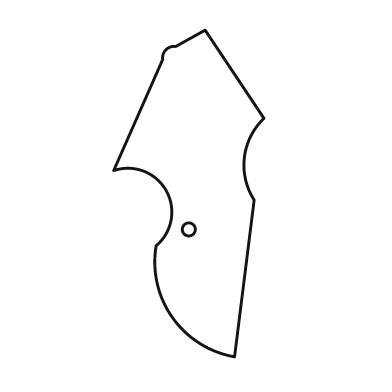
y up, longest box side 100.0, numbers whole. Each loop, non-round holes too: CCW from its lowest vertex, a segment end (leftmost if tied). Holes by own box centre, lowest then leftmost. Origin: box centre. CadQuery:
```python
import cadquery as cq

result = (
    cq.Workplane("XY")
    .moveTo(14.0, -50.0)
    .lineTo(20.0, -2.0)
    .threePointArc((17.0, 11.0), (23.0, 23.0))
    .lineTo(5.0, 50.0)
    .lineTo(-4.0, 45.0)
    .threePointArc((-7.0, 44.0), (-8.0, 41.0))
    .lineTo(-23.0, 7.0)
    .threePointArc((-7.0, 1.0), (-10.0, -16.0))
    .threePointArc((-5.0, -38.0), (14.0, -50.0))
    .close()
    .moveTo(0.0, -11.0)
    .circle(2.0)
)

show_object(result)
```